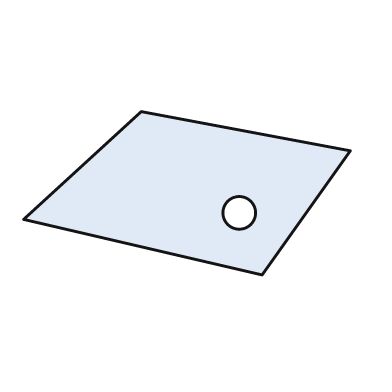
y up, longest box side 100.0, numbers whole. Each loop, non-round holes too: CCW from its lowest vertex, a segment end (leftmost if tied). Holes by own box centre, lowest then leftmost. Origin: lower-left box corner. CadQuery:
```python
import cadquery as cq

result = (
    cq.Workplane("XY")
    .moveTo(73.0, 0.0)
    .lineTo(100.0, 38.0)
    .lineTo(36.0, 50.0)
    .lineTo(0.0, 17.0)
    .close()
    .moveTo(66.0, 19.0)
    .circle(5.0)
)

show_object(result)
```